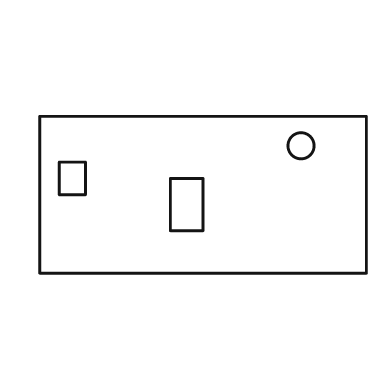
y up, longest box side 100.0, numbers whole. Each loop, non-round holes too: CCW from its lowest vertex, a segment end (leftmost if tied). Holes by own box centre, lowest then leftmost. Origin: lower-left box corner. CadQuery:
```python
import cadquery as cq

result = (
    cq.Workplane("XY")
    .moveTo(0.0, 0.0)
    .lineTo(100.0, 0.0)
    .lineTo(100.0, 48.0)
    .lineTo(0.0, 48.0)
    .close()
    .moveTo(40.0, 13.0)
    .lineTo(50.0, 13.0)
    .lineTo(50.0, 29.0)
    .lineTo(40.0, 29.0)
    .close()
    .moveTo(6.0, 24.0)
    .lineTo(14.0, 24.0)
    .lineTo(14.0, 34.0)
    .lineTo(6.0, 34.0)
    .close()
    .moveTo(80.0, 39.0)
    .circle(4.0)
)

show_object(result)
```